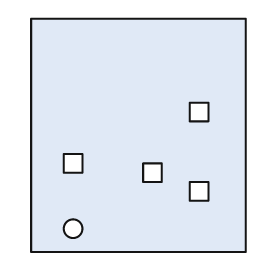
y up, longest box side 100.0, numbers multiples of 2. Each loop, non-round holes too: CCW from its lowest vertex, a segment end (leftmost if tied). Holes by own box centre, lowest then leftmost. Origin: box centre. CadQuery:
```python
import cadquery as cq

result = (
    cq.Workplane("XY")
    .moveTo(-46.0, -50.0)
    .lineTo(46.0, -50.0)
    .lineTo(46.0, 50.0)
    .lineTo(-46.0, 50.0)
    .close()
    .moveTo(-28.0, -40.0)
    .circle(4.0)
    .moveTo(22.0, -28.0)
    .lineTo(30.0, -28.0)
    .lineTo(30.0, -20.0)
    .lineTo(22.0, -20.0)
    .close()
    .moveTo(2.0, -20.0)
    .lineTo(10.0, -20.0)
    .lineTo(10.0, -12.0)
    .lineTo(2.0, -12.0)
    .close()
    .moveTo(-32.0, -16.0)
    .lineTo(-24.0, -16.0)
    .lineTo(-24.0, -8.0)
    .lineTo(-32.0, -8.0)
    .close()
    .moveTo(22.0, 6.0)
    .lineTo(30.0, 6.0)
    .lineTo(30.0, 14.0)
    .lineTo(22.0, 14.0)
    .close()
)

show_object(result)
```